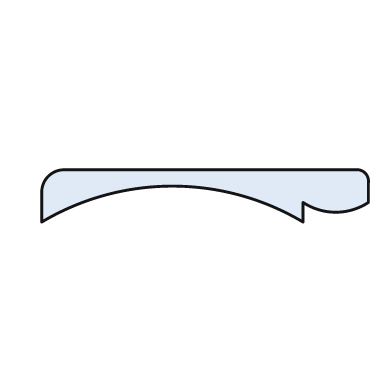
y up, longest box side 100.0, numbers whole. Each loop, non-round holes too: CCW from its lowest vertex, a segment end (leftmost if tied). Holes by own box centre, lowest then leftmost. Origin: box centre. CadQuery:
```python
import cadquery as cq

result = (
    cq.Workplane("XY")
    .moveTo(-50.0, -8.0)
    .threePointArc((-10.0, 3.0), (30.0, -8.0))
    .lineTo(30.0, -2.0)
    .threePointArc((40.0, -5.0), (50.0, -2.0))
    .lineTo(50.0, 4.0)
    .threePointArc((49.0, 7.0), (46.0, 8.0))
    .lineTo(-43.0, 8.0)
    .threePointArc((-48.0, 6.0), (-50.0, 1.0))
    .close()
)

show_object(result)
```